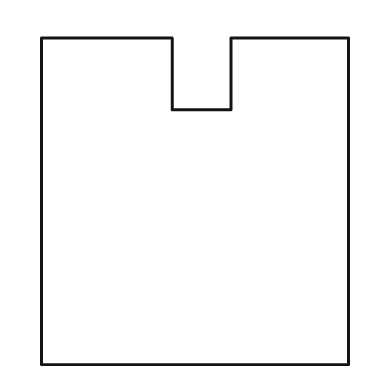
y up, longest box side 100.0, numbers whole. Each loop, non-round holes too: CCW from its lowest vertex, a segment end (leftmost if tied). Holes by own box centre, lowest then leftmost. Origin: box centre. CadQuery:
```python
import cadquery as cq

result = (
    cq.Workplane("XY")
    .moveTo(-47.0, -50.0)
    .lineTo(47.0, -50.0)
    .lineTo(47.0, 50.0)
    .lineTo(11.0, 50.0)
    .lineTo(11.0, 28.0)
    .lineTo(-7.0, 28.0)
    .lineTo(-7.0, 50.0)
    .lineTo(-47.0, 50.0)
    .close()
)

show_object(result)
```